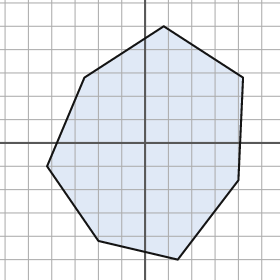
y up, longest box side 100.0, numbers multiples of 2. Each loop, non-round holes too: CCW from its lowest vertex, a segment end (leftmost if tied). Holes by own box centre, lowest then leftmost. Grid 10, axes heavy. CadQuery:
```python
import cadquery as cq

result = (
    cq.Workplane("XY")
    .moveTo(14.0, -50.0)
    .lineTo(40.0, -16.0)
    .lineTo(42.0, 28.0)
    .lineTo(8.0, 50.0)
    .lineTo(-26.0, 28.0)
    .lineTo(-42.0, -10.0)
    .lineTo(-20.0, -42.0)
    .close()
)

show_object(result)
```